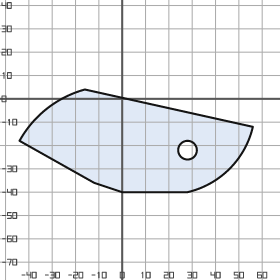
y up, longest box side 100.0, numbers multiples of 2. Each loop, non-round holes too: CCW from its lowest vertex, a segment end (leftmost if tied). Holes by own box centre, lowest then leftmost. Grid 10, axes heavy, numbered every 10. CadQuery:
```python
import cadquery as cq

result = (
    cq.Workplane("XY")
    .moveTo(0.0, -40.0)
    .lineTo(28.0, -40.0)
    .threePointArc((46.0, -30.0), (56.0, -12.0))
    .lineTo(-16.0, 4.0)
    .threePointArc((-32.0, -4.0), (-44.0, -18.0))
    .lineTo(-12.0, -36.0)
    .close()
    .moveTo(28.0, -22.0)
    .circle(4.0)
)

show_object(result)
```